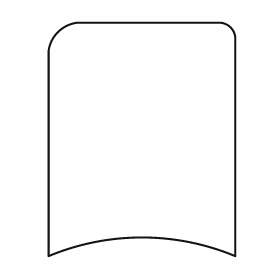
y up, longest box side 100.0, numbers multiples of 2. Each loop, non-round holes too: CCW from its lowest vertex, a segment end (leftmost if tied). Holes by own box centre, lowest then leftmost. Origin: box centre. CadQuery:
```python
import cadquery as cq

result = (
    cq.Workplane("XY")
    .moveTo(-40.0, -50.0)
    .threePointArc((0.0, -42.0), (40.0, -50.0))
    .lineTo(40.0, 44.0)
    .threePointArc((38.0, 48.0), (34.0, 50.0))
    .lineTo(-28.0, 50.0)
    .threePointArc((-36.0, 46.0), (-40.0, 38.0))
    .close()
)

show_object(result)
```